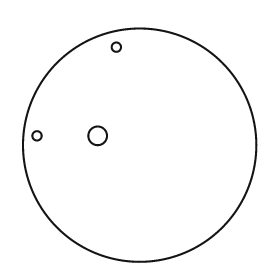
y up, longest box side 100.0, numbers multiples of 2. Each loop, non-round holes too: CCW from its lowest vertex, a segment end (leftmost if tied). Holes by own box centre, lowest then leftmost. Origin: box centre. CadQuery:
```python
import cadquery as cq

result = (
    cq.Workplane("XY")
    .moveTo(0.0, 0.0)
    .circle(50.0)
    .moveTo(-44.0, 4.0)
    .circle(2.0)
    .moveTo(-18.0, 4.0)
    .circle(4.0)
    .moveTo(-10.0, 42.0)
    .circle(2.0)
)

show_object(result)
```